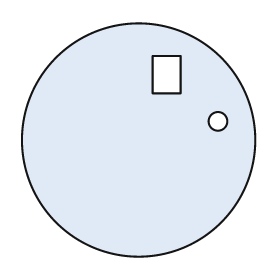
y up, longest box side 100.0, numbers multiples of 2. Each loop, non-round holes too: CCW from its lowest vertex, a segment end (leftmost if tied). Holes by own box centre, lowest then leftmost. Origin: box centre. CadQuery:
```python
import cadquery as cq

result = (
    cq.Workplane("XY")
    .moveTo(0.0, 0.0)
    .circle(50.0)
    .moveTo(34.0, 8.0)
    .circle(4.0)
    .moveTo(6.0, 20.0)
    .lineTo(18.0, 20.0)
    .lineTo(18.0, 36.0)
    .lineTo(6.0, 36.0)
    .close()
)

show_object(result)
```